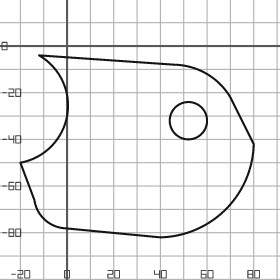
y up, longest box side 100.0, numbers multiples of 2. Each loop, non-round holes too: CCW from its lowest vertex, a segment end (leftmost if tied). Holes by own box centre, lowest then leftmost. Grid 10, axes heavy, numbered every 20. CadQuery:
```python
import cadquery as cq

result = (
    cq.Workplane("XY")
    .moveTo(40.0, -82.0)
    .threePointArc((68.0, -70.0), (80.0, -42.0))
    .lineTo(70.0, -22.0)
    .threePointArc((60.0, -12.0), (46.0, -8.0))
    .lineTo(-12.0, -4.0)
    .threePointArc((0.0, -30.0), (-20.0, -50.0))
    .lineTo(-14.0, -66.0)
    .threePointArc((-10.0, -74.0), (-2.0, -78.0))
    .close()
    .moveTo(52.0, -32.0)
    .circle(8.0)
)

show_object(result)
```